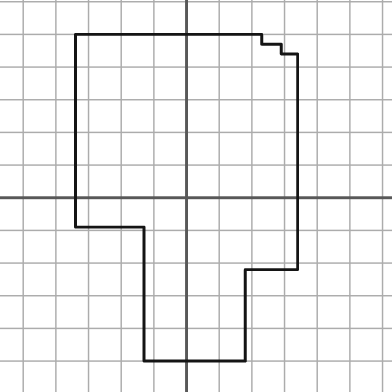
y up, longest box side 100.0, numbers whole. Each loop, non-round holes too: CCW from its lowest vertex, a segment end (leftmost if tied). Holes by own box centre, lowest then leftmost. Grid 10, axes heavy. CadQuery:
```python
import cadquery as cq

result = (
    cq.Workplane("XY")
    .moveTo(-13.0, -50.0)
    .lineTo(18.0, -50.0)
    .lineTo(18.0, -22.0)
    .lineTo(34.0, -22.0)
    .lineTo(34.0, 44.0)
    .lineTo(29.0, 44.0)
    .lineTo(29.0, 47.0)
    .lineTo(23.0, 47.0)
    .lineTo(23.0, 50.0)
    .lineTo(-34.0, 50.0)
    .lineTo(-34.0, -9.0)
    .lineTo(-13.0, -9.0)
    .close()
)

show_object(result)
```